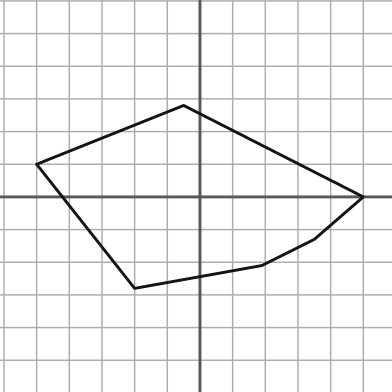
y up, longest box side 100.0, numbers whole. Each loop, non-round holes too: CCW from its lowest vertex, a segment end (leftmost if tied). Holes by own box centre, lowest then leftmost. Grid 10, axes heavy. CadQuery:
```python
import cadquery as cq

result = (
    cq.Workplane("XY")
    .moveTo(-20.0, -28.0)
    .lineTo(19.0, -21.0)
    .lineTo(35.0, -13.0)
    .lineTo(50.0, 0.0)
    .lineTo(-5.0, 28.0)
    .lineTo(-50.0, 10.0)
    .close()
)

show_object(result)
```